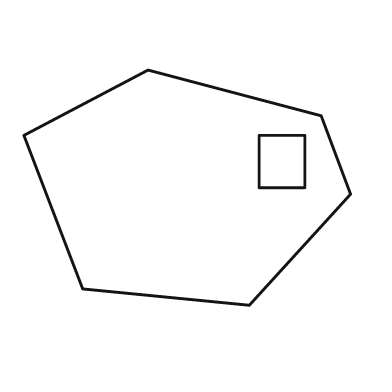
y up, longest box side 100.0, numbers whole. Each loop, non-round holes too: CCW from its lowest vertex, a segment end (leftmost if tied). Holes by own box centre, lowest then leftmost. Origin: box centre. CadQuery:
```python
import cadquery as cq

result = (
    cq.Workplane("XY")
    .moveTo(19.0, -36.0)
    .lineTo(50.0, -2.0)
    .lineTo(41.0, 22.0)
    .lineTo(-12.0, 36.0)
    .lineTo(-50.0, 16.0)
    .lineTo(-32.0, -31.0)
    .close()
    .moveTo(22.0, 0.0)
    .lineTo(36.0, 0.0)
    .lineTo(36.0, 16.0)
    .lineTo(22.0, 16.0)
    .close()
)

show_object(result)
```